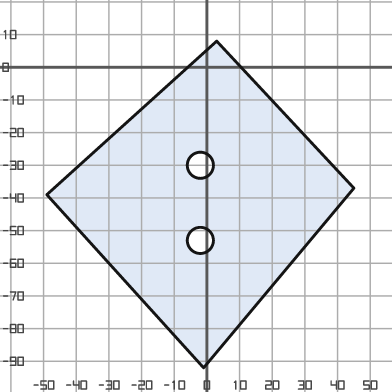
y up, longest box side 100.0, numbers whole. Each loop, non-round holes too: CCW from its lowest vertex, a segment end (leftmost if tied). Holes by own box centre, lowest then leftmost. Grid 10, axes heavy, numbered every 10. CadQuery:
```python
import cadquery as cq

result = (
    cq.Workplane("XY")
    .moveTo(-1.0, -92.0)
    .lineTo(45.0, -37.0)
    .lineTo(3.0, 8.0)
    .lineTo(-49.0, -39.0)
    .close()
    .moveTo(-2.0, -53.0)
    .circle(4.0)
    .moveTo(-2.0, -30.0)
    .circle(4.0)
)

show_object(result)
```